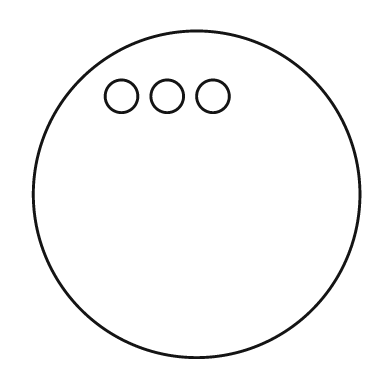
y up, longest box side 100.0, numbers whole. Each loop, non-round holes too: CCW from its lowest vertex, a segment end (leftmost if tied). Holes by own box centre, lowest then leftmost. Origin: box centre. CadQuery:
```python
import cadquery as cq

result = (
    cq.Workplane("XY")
    .moveTo(0.0, 0.0)
    .circle(50.0)
    .moveTo(-23.0, 30.0)
    .circle(5.0)
    .moveTo(-9.0, 30.0)
    .circle(5.0)
    .moveTo(5.0, 30.0)
    .circle(5.0)
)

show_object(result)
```